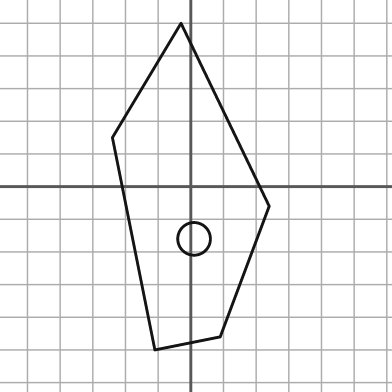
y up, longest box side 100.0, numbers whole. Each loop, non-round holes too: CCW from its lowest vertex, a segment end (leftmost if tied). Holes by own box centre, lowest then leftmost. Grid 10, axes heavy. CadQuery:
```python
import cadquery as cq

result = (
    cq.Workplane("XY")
    .moveTo(-11.0, -50.0)
    .lineTo(9.0, -46.0)
    .lineTo(24.0, -6.0)
    .lineTo(-3.0, 50.0)
    .lineTo(-24.0, 15.0)
    .close()
    .moveTo(1.0, -16.0)
    .circle(5.0)
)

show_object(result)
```